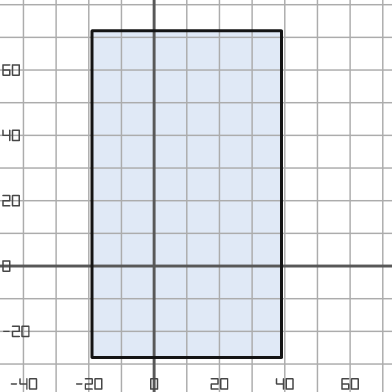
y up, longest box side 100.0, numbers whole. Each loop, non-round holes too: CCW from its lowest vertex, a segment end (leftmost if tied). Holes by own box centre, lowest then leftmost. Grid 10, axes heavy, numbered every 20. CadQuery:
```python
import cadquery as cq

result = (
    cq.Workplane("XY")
    .moveTo(-19.0, -28.0)
    .lineTo(39.0, -28.0)
    .lineTo(39.0, 72.0)
    .lineTo(-19.0, 72.0)
    .close()
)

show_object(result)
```